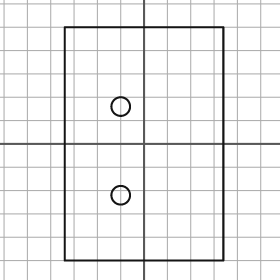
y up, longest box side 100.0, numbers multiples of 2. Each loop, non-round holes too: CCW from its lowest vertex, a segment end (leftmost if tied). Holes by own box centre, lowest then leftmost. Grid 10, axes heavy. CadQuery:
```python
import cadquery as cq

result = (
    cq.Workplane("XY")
    .moveTo(-34.0, -50.0)
    .lineTo(34.0, -50.0)
    .lineTo(34.0, 50.0)
    .lineTo(-34.0, 50.0)
    .close()
    .moveTo(-10.0, -22.0)
    .circle(4.0)
    .moveTo(-10.0, 16.0)
    .circle(4.0)
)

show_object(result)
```